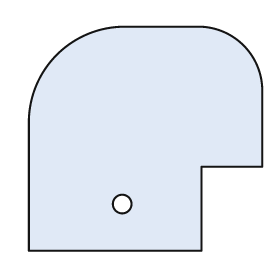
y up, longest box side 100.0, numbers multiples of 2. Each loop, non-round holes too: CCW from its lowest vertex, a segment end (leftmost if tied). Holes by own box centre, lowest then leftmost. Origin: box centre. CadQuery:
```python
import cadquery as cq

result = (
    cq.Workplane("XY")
    .moveTo(-50.0, -48.0)
    .lineTo(24.0, -48.0)
    .lineTo(24.0, -12.0)
    .lineTo(50.0, -12.0)
    .lineTo(50.0, 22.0)
    .threePointArc((42.0, 40.0), (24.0, 48.0))
    .lineTo(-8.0, 48.0)
    .threePointArc((-38.0, 36.0), (-50.0, 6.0))
    .close()
    .moveTo(-10.0, -28.0)
    .circle(4.0)
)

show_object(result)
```